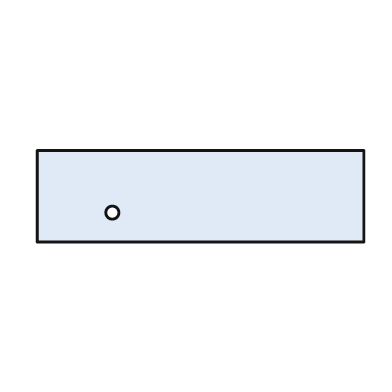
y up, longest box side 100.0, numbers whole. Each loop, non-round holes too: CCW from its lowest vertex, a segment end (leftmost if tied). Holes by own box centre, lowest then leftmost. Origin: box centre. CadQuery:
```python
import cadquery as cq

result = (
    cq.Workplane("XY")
    .moveTo(-50.0, -14.0)
    .lineTo(50.0, -14.0)
    .lineTo(50.0, 14.0)
    .lineTo(-50.0, 14.0)
    .close()
    .moveTo(-27.0, -5.0)
    .circle(2.0)
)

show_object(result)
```